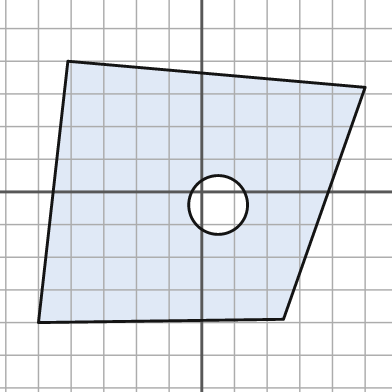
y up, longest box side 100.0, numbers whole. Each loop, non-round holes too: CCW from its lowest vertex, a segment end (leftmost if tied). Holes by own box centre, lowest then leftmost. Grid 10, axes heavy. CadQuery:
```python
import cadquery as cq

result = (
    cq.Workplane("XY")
    .moveTo(-50.0, -40.0)
    .lineTo(25.0, -39.0)
    .lineTo(50.0, 32.0)
    .lineTo(-41.0, 40.0)
    .close()
    .moveTo(5.0, -4.0)
    .circle(9.0)
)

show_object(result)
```